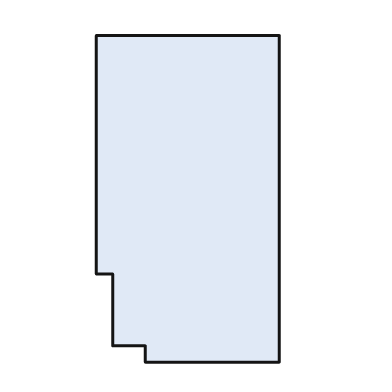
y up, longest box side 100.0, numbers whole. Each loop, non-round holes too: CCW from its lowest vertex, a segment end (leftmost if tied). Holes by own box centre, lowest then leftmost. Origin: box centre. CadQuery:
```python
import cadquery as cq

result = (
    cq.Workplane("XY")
    .moveTo(-13.0, -50.0)
    .lineTo(28.0, -50.0)
    .lineTo(28.0, 50.0)
    .lineTo(-28.0, 50.0)
    .lineTo(-28.0, -23.0)
    .lineTo(-23.0, -23.0)
    .lineTo(-23.0, -45.0)
    .lineTo(-13.0, -45.0)
    .close()
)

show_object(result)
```